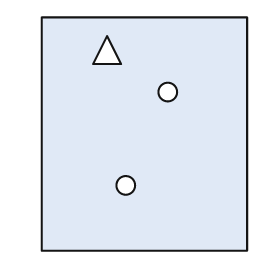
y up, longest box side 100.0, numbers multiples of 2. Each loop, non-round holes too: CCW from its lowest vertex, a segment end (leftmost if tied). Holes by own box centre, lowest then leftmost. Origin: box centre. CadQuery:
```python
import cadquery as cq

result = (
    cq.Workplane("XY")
    .moveTo(-44.0, -50.0)
    .lineTo(44.0, -50.0)
    .lineTo(44.0, 50.0)
    .lineTo(-44.0, 50.0)
    .close()
    .moveTo(-8.0, -22.0)
    .circle(4.0)
    .moveTo(10.0, 18.0)
    .circle(4.0)
    .moveTo(-22.0, 30.0)
    .lineTo(-10.0, 30.0)
    .lineTo(-16.0, 42.0)
    .close()
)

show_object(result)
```